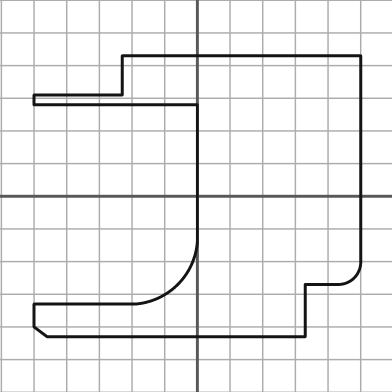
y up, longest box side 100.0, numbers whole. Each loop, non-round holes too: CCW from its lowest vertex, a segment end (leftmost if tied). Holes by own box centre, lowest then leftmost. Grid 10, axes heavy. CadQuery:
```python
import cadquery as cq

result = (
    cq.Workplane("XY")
    .moveTo(-46.0, -43.0)
    .lineTo(33.0, -43.0)
    .lineTo(33.0, -27.0)
    .lineTo(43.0, -27.0)
    .threePointArc((48.0, -25.0), (50.0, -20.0))
    .lineTo(50.0, 43.0)
    .lineTo(-23.0, 43.0)
    .lineTo(-23.0, 31.0)
    .lineTo(-50.0, 31.0)
    .lineTo(-50.0, 28.0)
    .lineTo(0.0, 28.0)
    .lineTo(0.0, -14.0)
    .threePointArc((-6.0, -27.0), (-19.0, -33.0))
    .lineTo(-50.0, -33.0)
    .lineTo(-50.0, -40.0)
    .close()
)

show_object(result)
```